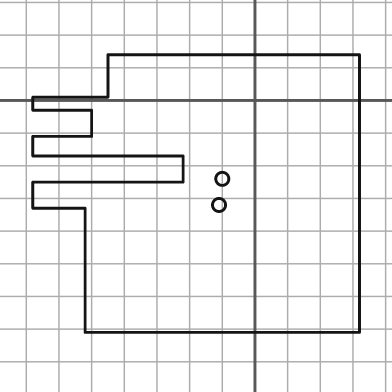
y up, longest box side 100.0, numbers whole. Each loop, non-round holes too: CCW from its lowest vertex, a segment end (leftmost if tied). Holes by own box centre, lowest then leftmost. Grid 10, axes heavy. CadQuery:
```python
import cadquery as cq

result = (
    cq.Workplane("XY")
    .moveTo(-52.0, -71.0)
    .lineTo(32.0, -71.0)
    .lineTo(32.0, 14.0)
    .lineTo(-45.0, 14.0)
    .lineTo(-45.0, 1.0)
    .lineTo(-68.0, 1.0)
    .lineTo(-68.0, -3.0)
    .lineTo(-50.0, -3.0)
    .lineTo(-50.0, -11.0)
    .lineTo(-68.0, -11.0)
    .lineTo(-68.0, -17.0)
    .lineTo(-22.0, -17.0)
    .lineTo(-22.0, -25.0)
    .lineTo(-68.0, -25.0)
    .lineTo(-68.0, -33.0)
    .lineTo(-52.0, -33.0)
    .close()
    .moveTo(-11.0, -32.0)
    .circle(2.0)
    .moveTo(-10.0, -24.0)
    .circle(2.0)
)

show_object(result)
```